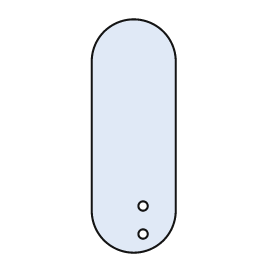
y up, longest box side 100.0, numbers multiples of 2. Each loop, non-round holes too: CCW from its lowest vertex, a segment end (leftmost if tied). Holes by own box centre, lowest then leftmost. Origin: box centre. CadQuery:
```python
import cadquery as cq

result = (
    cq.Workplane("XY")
    .moveTo(-18.0, -32.0)
    .threePointArc((0.0, -50.0), (18.0, -32.0))
    .lineTo(18.0, 32.0)
    .threePointArc((0.0, 50.0), (-18.0, 32.0))
    .close()
    .moveTo(4.0, -42.0)
    .circle(2.0)
    .moveTo(4.0, -30.0)
    .circle(2.0)
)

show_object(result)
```